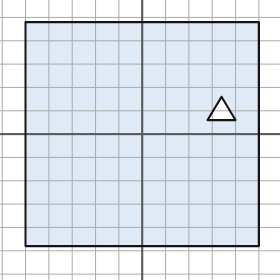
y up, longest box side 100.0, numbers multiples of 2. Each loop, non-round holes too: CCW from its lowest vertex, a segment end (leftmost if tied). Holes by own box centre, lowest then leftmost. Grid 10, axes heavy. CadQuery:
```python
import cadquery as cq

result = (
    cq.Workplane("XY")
    .moveTo(-50.0, -48.0)
    .lineTo(50.0, -48.0)
    .lineTo(50.0, 48.0)
    .lineTo(-50.0, 48.0)
    .close()
    .moveTo(28.0, 6.0)
    .lineTo(40.0, 6.0)
    .lineTo(34.0, 16.0)
    .close()
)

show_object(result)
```